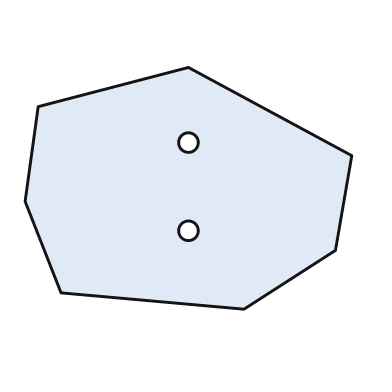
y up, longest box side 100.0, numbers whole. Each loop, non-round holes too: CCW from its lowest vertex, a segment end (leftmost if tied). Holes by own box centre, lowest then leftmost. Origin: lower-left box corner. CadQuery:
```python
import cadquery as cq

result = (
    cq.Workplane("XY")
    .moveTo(67.0, 0.0)
    .lineTo(95.0, 18.0)
    .lineTo(100.0, 47.0)
    .lineTo(50.0, 74.0)
    .lineTo(4.0, 62.0)
    .lineTo(0.0, 33.0)
    .lineTo(11.0, 5.0)
    .close()
    .moveTo(50.0, 24.0)
    .circle(3.0)
    .moveTo(50.0, 51.0)
    .circle(3.0)
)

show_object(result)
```